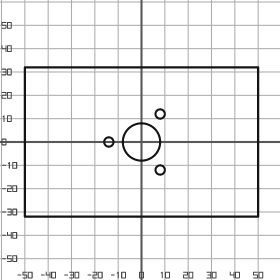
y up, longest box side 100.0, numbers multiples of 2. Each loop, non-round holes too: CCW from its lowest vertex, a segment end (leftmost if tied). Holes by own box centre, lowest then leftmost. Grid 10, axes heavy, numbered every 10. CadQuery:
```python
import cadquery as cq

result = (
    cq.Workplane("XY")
    .moveTo(-50.0, -32.0)
    .lineTo(50.0, -32.0)
    .lineTo(50.0, 32.0)
    .lineTo(-50.0, 32.0)
    .close()
    .moveTo(8.0, -12.0)
    .circle(2.0)
    .moveTo(-14.0, 0.0)
    .circle(2.0)
    .moveTo(0.0, 0.0)
    .circle(8.0)
    .moveTo(8.0, 12.0)
    .circle(2.0)
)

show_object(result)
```